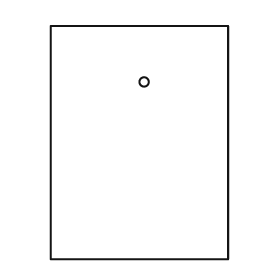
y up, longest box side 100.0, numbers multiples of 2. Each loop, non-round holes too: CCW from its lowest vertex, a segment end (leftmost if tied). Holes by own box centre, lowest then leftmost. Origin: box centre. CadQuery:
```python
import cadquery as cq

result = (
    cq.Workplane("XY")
    .moveTo(-38.0, -50.0)
    .lineTo(38.0, -50.0)
    .lineTo(38.0, 50.0)
    .lineTo(-38.0, 50.0)
    .close()
    .moveTo(2.0, 26.0)
    .circle(2.0)
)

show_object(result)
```